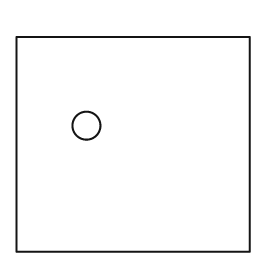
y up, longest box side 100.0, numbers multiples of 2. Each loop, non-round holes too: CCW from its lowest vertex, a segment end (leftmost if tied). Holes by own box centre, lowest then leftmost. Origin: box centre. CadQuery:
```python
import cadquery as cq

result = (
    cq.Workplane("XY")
    .moveTo(-50.0, -46.0)
    .lineTo(50.0, -46.0)
    .lineTo(50.0, 46.0)
    .lineTo(-50.0, 46.0)
    .close()
    .moveTo(-20.0, 8.0)
    .circle(6.0)
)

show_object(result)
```